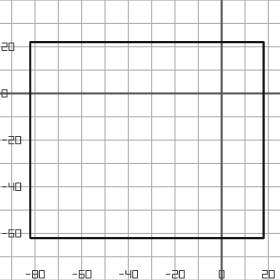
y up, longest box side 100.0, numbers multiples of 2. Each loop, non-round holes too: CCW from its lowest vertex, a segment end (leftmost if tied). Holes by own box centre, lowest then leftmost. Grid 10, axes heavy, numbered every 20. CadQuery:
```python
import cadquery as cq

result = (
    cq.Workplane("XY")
    .moveTo(-82.0, -62.0)
    .lineTo(18.0, -62.0)
    .lineTo(18.0, 22.0)
    .lineTo(-82.0, 22.0)
    .close()
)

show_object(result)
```